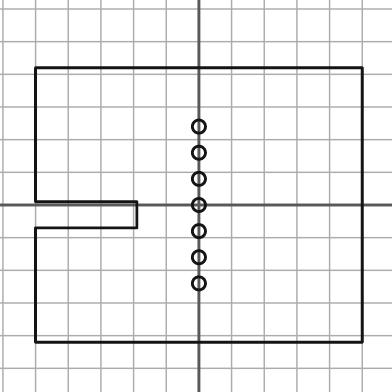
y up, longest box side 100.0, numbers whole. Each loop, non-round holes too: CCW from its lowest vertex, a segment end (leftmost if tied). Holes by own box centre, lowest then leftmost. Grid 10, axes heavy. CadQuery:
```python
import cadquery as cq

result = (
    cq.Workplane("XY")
    .moveTo(-50.0, -42.0)
    .lineTo(50.0, -42.0)
    .lineTo(50.0, 42.0)
    .lineTo(-50.0, 42.0)
    .lineTo(-50.0, 1.0)
    .lineTo(-19.0, 1.0)
    .lineTo(-19.0, -7.0)
    .lineTo(-50.0, -7.0)
    .close()
    .moveTo(0.0, -24.0)
    .circle(2.0)
    .moveTo(0.0, -16.0)
    .circle(2.0)
    .moveTo(0.0, -8.0)
    .circle(2.0)
    .moveTo(0.0, 0.0)
    .circle(2.0)
    .moveTo(0.0, 8.0)
    .circle(2.0)
    .moveTo(0.0, 16.0)
    .circle(2.0)
    .moveTo(0.0, 24.0)
    .circle(2.0)
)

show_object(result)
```